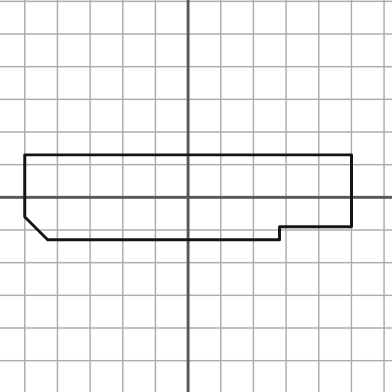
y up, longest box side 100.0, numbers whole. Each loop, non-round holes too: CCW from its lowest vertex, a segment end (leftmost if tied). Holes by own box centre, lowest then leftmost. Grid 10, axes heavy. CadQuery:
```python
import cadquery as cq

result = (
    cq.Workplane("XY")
    .moveTo(-43.0, -13.0)
    .lineTo(28.0, -13.0)
    .lineTo(28.0, -9.0)
    .lineTo(50.0, -9.0)
    .lineTo(50.0, 13.0)
    .lineTo(-50.0, 13.0)
    .lineTo(-50.0, -6.0)
    .close()
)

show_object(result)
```